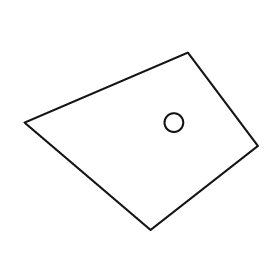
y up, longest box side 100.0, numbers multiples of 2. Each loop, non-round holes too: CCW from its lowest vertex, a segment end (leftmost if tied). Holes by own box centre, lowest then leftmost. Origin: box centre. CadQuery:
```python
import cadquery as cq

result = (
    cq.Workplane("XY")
    .moveTo(4.0, -38.0)
    .lineTo(50.0, -2.0)
    .lineTo(20.0, 38.0)
    .lineTo(-50.0, 8.0)
    .close()
    .moveTo(14.0, 8.0)
    .circle(4.0)
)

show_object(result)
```